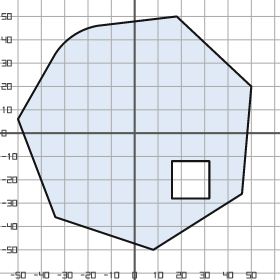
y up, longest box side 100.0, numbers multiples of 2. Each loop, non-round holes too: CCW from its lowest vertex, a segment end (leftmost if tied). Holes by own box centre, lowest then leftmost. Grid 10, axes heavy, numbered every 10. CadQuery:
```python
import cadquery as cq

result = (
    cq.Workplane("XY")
    .moveTo(8.0, -50.0)
    .lineTo(46.0, -26.0)
    .lineTo(50.0, 20.0)
    .lineTo(18.0, 50.0)
    .lineTo(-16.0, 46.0)
    .threePointArc((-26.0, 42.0), (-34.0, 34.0))
    .lineTo(-50.0, 6.0)
    .lineTo(-34.0, -36.0)
    .close()
    .moveTo(16.0, -28.0)
    .lineTo(32.0, -28.0)
    .lineTo(32.0, -12.0)
    .lineTo(16.0, -12.0)
    .close()
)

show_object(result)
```